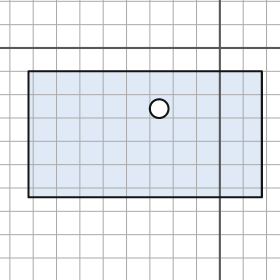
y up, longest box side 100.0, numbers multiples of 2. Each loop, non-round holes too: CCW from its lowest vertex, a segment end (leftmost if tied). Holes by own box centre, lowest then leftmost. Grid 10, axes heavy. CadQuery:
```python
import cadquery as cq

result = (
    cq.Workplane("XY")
    .moveTo(-82.0, -64.0)
    .lineTo(18.0, -64.0)
    .lineTo(18.0, -10.0)
    .lineTo(-82.0, -10.0)
    .close()
    .moveTo(-26.0, -26.0)
    .circle(4.0)
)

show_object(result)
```